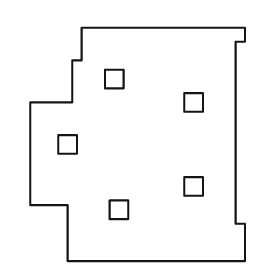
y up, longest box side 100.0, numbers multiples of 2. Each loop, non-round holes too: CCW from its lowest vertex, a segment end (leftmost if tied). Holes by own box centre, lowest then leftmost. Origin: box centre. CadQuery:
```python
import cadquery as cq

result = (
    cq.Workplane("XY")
    .moveTo(-30.0, -50.0)
    .lineTo(46.0, -50.0)
    .lineTo(46.0, -34.0)
    .lineTo(42.0, -34.0)
    .lineTo(42.0, 44.0)
    .lineTo(46.0, 44.0)
    .lineTo(46.0, 50.0)
    .lineTo(-24.0, 50.0)
    .lineTo(-24.0, 36.0)
    .lineTo(-28.0, 36.0)
    .lineTo(-28.0, 18.0)
    .lineTo(-46.0, 18.0)
    .lineTo(-46.0, -26.0)
    .lineTo(-30.0, -26.0)
    .close()
    .moveTo(-12.0, -32.0)
    .lineTo(-4.0, -32.0)
    .lineTo(-4.0, -24.0)
    .lineTo(-12.0, -24.0)
    .close()
    .moveTo(20.0, -22.0)
    .lineTo(28.0, -22.0)
    .lineTo(28.0, -14.0)
    .lineTo(20.0, -14.0)
    .close()
    .moveTo(-34.0, -4.0)
    .lineTo(-26.0, -4.0)
    .lineTo(-26.0, 4.0)
    .lineTo(-34.0, 4.0)
    .close()
    .moveTo(20.0, 14.0)
    .lineTo(28.0, 14.0)
    .lineTo(28.0, 22.0)
    .lineTo(20.0, 22.0)
    .close()
    .moveTo(-14.0, 24.0)
    .lineTo(-6.0, 24.0)
    .lineTo(-6.0, 32.0)
    .lineTo(-14.0, 32.0)
    .close()
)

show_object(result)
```